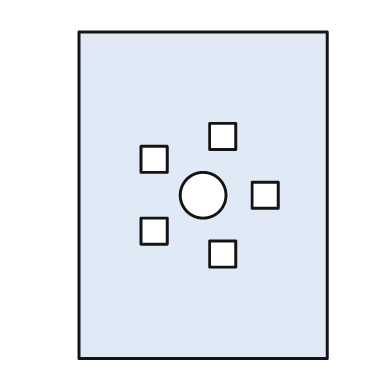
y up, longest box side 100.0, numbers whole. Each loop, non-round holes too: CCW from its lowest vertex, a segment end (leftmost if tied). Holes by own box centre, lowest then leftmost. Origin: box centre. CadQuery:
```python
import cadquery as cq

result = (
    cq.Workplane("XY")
    .moveTo(-38.0, -50.0)
    .lineTo(38.0, -50.0)
    .lineTo(38.0, 50.0)
    .lineTo(-38.0, 50.0)
    .close()
    .moveTo(2.0, -22.0)
    .lineTo(10.0, -22.0)
    .lineTo(10.0, -14.0)
    .lineTo(2.0, -14.0)
    .close()
    .moveTo(-19.0, -15.0)
    .lineTo(-11.0, -15.0)
    .lineTo(-11.0, -7.0)
    .lineTo(-19.0, -7.0)
    .close()
    .moveTo(0.0, 0.0)
    .circle(7.0)
    .moveTo(15.0, -4.0)
    .lineTo(23.0, -4.0)
    .lineTo(23.0, 4.0)
    .lineTo(15.0, 4.0)
    .close()
    .moveTo(-19.0, 7.0)
    .lineTo(-11.0, 7.0)
    .lineTo(-11.0, 15.0)
    .lineTo(-19.0, 15.0)
    .close()
    .moveTo(2.0, 14.0)
    .lineTo(10.0, 14.0)
    .lineTo(10.0, 22.0)
    .lineTo(2.0, 22.0)
    .close()
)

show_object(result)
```